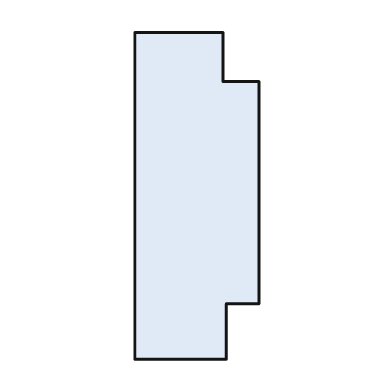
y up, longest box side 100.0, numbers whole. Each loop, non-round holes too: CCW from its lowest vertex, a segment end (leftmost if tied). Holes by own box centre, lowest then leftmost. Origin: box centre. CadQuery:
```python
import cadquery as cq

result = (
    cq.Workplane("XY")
    .moveTo(-19.0, -50.0)
    .lineTo(9.0, -50.0)
    .lineTo(9.0, -33.0)
    .lineTo(19.0, -33.0)
    .lineTo(19.0, 35.0)
    .lineTo(8.0, 35.0)
    .lineTo(8.0, 50.0)
    .lineTo(-19.0, 50.0)
    .close()
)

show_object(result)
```